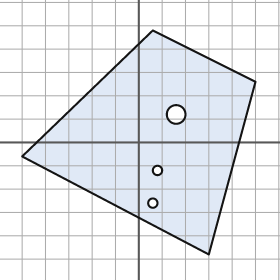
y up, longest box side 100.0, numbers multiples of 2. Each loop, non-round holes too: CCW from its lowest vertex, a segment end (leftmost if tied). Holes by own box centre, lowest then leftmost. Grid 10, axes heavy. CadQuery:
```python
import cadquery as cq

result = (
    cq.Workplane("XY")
    .moveTo(30.0, -48.0)
    .lineTo(50.0, 26.0)
    .lineTo(6.0, 48.0)
    .lineTo(-50.0, -6.0)
    .close()
    .moveTo(6.0, -26.0)
    .circle(2.0)
    .moveTo(8.0, -12.0)
    .circle(2.0)
    .moveTo(16.0, 12.0)
    .circle(4.0)
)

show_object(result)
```